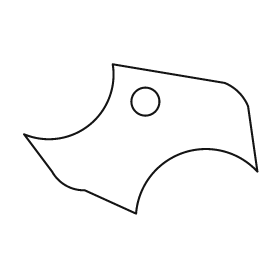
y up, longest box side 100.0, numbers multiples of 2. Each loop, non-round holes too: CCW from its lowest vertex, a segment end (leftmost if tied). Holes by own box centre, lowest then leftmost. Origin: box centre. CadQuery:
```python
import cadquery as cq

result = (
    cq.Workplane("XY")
    .moveTo(-2.0, -32.0)
    .threePointArc((18.0, -6.0), (50.0, -14.0))
    .lineTo(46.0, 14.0)
    .threePointArc((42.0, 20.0), (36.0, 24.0))
    .lineTo(-12.0, 32.0)
    .threePointArc((-22.0, 6.0), (-50.0, 2.0))
    .lineTo(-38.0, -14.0)
    .threePointArc((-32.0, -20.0), (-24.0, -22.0))
    .close()
    .moveTo(2.0, 16.0)
    .circle(6.0)
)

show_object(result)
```